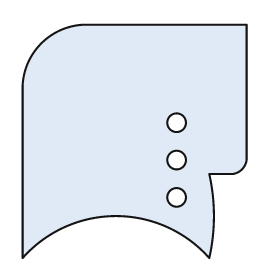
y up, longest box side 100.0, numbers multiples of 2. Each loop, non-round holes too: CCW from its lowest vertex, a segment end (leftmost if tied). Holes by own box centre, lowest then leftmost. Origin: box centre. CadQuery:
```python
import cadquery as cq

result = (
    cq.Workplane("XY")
    .moveTo(-48.0, -50.0)
    .threePointArc((-8.0, -32.0), (32.0, -50.0))
    .threePointArc((34.0, -32.0), (32.0, -14.0))
    .lineTo(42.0, -14.0)
    .threePointArc((46.0, -12.0), (48.0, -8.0))
    .lineTo(48.0, 50.0)
    .lineTo(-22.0, 50.0)
    .threePointArc((-40.0, 42.0), (-48.0, 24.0))
    .close()
    .moveTo(18.0, -24.0)
    .circle(4.0)
    .moveTo(18.0, -8.0)
    .circle(4.0)
    .moveTo(18.0, 8.0)
    .circle(4.0)
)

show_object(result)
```